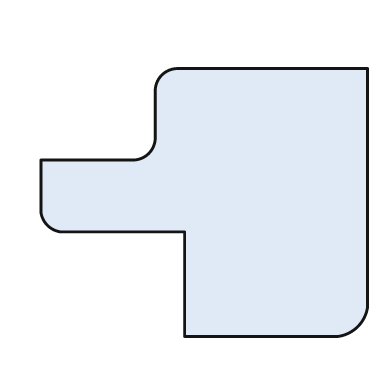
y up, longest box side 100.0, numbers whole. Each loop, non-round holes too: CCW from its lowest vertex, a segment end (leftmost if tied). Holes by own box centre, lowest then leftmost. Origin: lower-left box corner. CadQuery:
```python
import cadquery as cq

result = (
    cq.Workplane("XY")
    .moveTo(44.0, 0.0)
    .lineTo(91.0, 0.0)
    .threePointArc((97.0, 3.0), (100.0, 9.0))
    .lineTo(100.0, 82.0)
    .lineTo(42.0, 82.0)
    .threePointArc((37.0, 80.0), (35.0, 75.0))
    .lineTo(35.0, 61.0)
    .threePointArc((33.0, 56.0), (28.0, 54.0))
    .lineTo(0.0, 54.0)
    .lineTo(0.0, 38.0)
    .threePointArc((2.0, 34.0), (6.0, 32.0))
    .lineTo(44.0, 32.0)
    .close()
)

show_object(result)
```